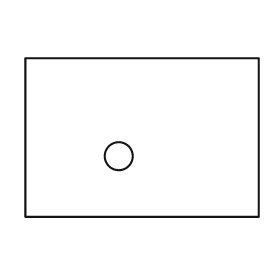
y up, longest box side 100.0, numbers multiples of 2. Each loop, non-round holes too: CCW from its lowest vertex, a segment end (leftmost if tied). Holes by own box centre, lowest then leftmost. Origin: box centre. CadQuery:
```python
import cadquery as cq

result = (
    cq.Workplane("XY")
    .moveTo(-50.0, -34.0)
    .lineTo(50.0, -34.0)
    .lineTo(50.0, 34.0)
    .lineTo(-50.0, 34.0)
    .close()
    .moveTo(-10.0, -8.0)
    .circle(6.0)
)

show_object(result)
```